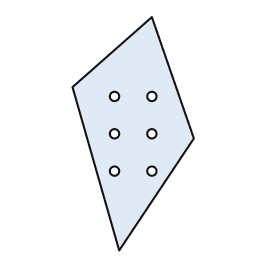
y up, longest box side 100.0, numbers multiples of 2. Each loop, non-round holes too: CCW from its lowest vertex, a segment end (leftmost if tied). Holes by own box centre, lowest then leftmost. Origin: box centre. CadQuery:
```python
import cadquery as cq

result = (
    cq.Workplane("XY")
    .moveTo(-6.0, -50.0)
    .lineTo(26.0, -2.0)
    .lineTo(8.0, 50.0)
    .lineTo(-26.0, 20.0)
    .close()
    .moveTo(-8.0, -16.0)
    .circle(2.0)
    .moveTo(8.0, -16.0)
    .circle(2.0)
    .moveTo(-8.0, 0.0)
    .circle(2.0)
    .moveTo(8.0, 0.0)
    .circle(2.0)
    .moveTo(-8.0, 16.0)
    .circle(2.0)
    .moveTo(8.0, 16.0)
    .circle(2.0)
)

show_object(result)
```